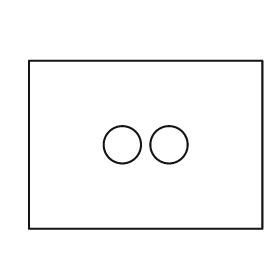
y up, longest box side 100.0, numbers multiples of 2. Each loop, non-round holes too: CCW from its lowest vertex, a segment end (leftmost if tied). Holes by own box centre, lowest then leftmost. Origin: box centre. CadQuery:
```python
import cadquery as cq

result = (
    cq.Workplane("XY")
    .moveTo(-50.0, -36.0)
    .lineTo(50.0, -36.0)
    .lineTo(50.0, 36.0)
    .lineTo(-50.0, 36.0)
    .close()
    .moveTo(-10.0, 0.0)
    .circle(8.0)
    .moveTo(10.0, 0.0)
    .circle(8.0)
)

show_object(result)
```